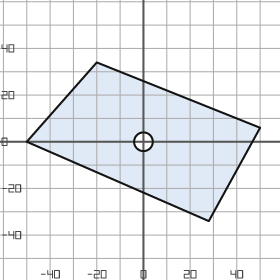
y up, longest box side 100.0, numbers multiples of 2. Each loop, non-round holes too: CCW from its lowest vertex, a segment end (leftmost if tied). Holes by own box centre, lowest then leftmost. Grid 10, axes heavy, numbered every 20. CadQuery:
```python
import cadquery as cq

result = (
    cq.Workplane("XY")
    .moveTo(28.0, -34.0)
    .lineTo(50.0, 6.0)
    .lineTo(-20.0, 34.0)
    .lineTo(-50.0, 0.0)
    .close()
    .moveTo(0.0, 0.0)
    .circle(4.0)
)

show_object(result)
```